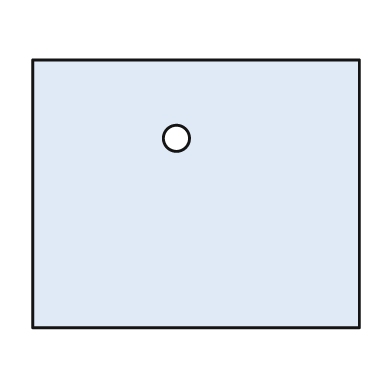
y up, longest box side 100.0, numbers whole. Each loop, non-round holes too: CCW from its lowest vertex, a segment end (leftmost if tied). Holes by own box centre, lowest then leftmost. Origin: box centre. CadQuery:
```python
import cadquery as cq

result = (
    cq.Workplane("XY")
    .moveTo(-50.0, -41.0)
    .lineTo(50.0, -41.0)
    .lineTo(50.0, 41.0)
    .lineTo(-50.0, 41.0)
    .close()
    .moveTo(-6.0, 17.0)
    .circle(4.0)
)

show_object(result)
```